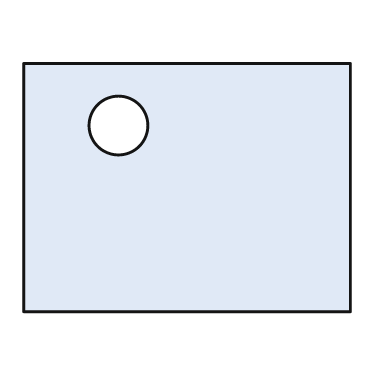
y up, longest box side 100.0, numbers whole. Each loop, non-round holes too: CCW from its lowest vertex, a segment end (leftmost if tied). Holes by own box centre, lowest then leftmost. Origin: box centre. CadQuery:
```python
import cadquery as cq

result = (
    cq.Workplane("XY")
    .moveTo(-50.0, -38.0)
    .lineTo(50.0, -38.0)
    .lineTo(50.0, 38.0)
    .lineTo(-50.0, 38.0)
    .close()
    .moveTo(-21.0, 19.0)
    .circle(9.0)
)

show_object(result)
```